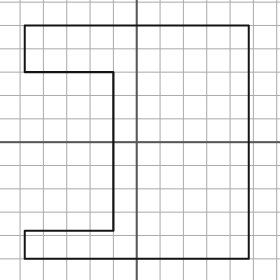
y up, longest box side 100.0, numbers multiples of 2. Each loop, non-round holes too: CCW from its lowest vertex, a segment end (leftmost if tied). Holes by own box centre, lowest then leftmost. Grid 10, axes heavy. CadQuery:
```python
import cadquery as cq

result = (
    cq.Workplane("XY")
    .moveTo(-48.0, -50.0)
    .lineTo(48.0, -50.0)
    .lineTo(48.0, 50.0)
    .lineTo(-48.0, 50.0)
    .lineTo(-48.0, 30.0)
    .lineTo(-10.0, 30.0)
    .lineTo(-10.0, -38.0)
    .lineTo(-48.0, -38.0)
    .close()
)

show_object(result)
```